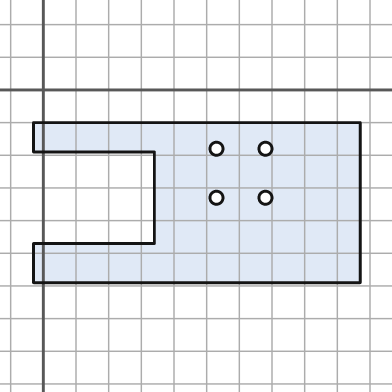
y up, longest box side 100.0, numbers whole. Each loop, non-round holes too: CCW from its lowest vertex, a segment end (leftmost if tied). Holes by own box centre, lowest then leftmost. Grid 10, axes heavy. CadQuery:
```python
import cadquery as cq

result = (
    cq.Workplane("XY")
    .moveTo(-3.0, -59.0)
    .lineTo(97.0, -59.0)
    .lineTo(97.0, -10.0)
    .lineTo(-3.0, -10.0)
    .lineTo(-3.0, -19.0)
    .lineTo(34.0, -19.0)
    .lineTo(34.0, -47.0)
    .lineTo(-3.0, -47.0)
    .close()
    .moveTo(53.0, -33.0)
    .circle(2.0)
    .moveTo(68.0, -33.0)
    .circle(2.0)
    .moveTo(53.0, -18.0)
    .circle(2.0)
    .moveTo(68.0, -18.0)
    .circle(2.0)
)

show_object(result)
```